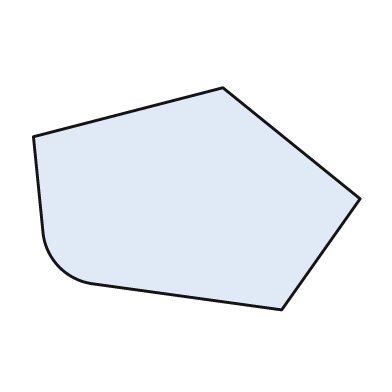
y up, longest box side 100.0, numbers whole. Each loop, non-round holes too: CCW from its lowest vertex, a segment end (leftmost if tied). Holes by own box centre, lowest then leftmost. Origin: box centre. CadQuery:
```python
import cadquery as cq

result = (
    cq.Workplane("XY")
    .moveTo(26.0, -34.0)
    .lineTo(50.0, 0.0)
    .lineTo(8.0, 34.0)
    .lineTo(-50.0, 19.0)
    .lineTo(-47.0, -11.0)
    .threePointArc((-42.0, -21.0), (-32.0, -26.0))
    .close()
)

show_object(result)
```